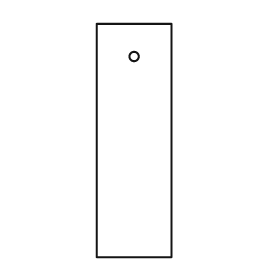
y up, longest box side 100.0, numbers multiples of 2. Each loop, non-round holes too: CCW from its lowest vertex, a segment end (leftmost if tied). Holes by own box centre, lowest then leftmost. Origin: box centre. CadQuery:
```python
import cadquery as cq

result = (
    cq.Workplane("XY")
    .moveTo(-16.0, -50.0)
    .lineTo(16.0, -50.0)
    .lineTo(16.0, 50.0)
    .lineTo(-16.0, 50.0)
    .close()
    .moveTo(0.0, 36.0)
    .circle(2.0)
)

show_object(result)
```